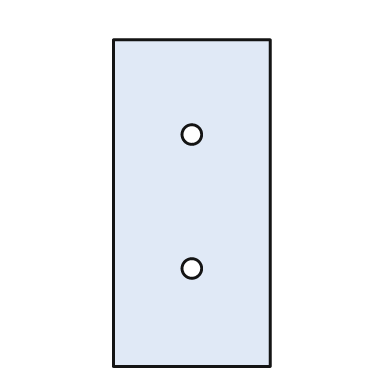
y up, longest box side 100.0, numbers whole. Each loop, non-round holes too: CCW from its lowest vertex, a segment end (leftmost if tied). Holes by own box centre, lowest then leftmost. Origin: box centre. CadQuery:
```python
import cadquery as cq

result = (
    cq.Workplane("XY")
    .moveTo(-24.0, -50.0)
    .lineTo(24.0, -50.0)
    .lineTo(24.0, 50.0)
    .lineTo(-24.0, 50.0)
    .close()
    .moveTo(0.0, -20.0)
    .circle(3.0)
    .moveTo(0.0, 21.0)
    .circle(3.0)
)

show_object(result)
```